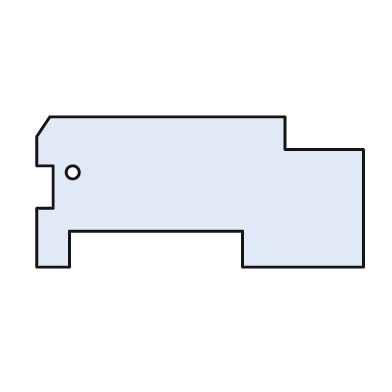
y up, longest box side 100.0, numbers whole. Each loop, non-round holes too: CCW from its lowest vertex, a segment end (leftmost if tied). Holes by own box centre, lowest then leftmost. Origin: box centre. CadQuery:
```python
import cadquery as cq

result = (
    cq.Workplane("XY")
    .moveTo(-50.0, -23.0)
    .lineTo(-40.0, -23.0)
    .lineTo(-40.0, -12.0)
    .lineTo(13.0, -12.0)
    .lineTo(13.0, -23.0)
    .lineTo(50.0, -23.0)
    .lineTo(50.0, 13.0)
    .lineTo(26.0, 13.0)
    .lineTo(26.0, 23.0)
    .lineTo(-46.0, 23.0)
    .lineTo(-50.0, 17.0)
    .lineTo(-50.0, 8.0)
    .lineTo(-45.0, 8.0)
    .lineTo(-45.0, -5.0)
    .lineTo(-50.0, -5.0)
    .close()
    .moveTo(-39.0, 6.0)
    .circle(2.0)
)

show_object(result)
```